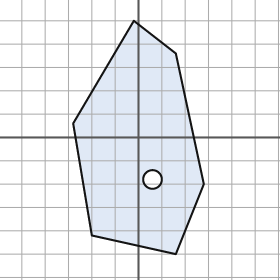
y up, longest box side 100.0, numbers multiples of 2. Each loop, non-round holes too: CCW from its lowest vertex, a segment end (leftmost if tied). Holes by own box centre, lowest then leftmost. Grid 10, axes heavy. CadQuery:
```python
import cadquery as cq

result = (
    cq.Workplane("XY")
    .moveTo(16.0, -50.0)
    .lineTo(28.0, -20.0)
    .lineTo(16.0, 36.0)
    .lineTo(-2.0, 50.0)
    .lineTo(-28.0, 6.0)
    .lineTo(-20.0, -42.0)
    .close()
    .moveTo(6.0, -18.0)
    .circle(4.0)
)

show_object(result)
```